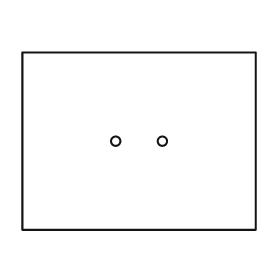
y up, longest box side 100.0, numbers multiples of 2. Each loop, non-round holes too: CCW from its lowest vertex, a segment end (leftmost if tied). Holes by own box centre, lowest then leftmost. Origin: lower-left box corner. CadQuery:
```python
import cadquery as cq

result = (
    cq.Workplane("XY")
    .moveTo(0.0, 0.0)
    .lineTo(100.0, 0.0)
    .lineTo(100.0, 76.0)
    .lineTo(0.0, 76.0)
    .close()
    .moveTo(40.0, 38.0)
    .circle(2.0)
    .moveTo(60.0, 38.0)
    .circle(2.0)
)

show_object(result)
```